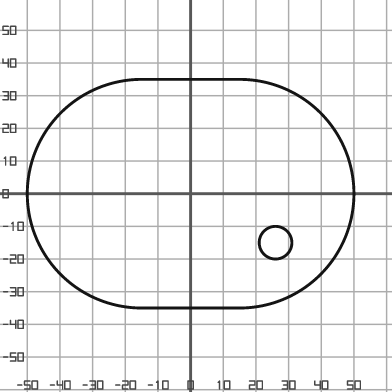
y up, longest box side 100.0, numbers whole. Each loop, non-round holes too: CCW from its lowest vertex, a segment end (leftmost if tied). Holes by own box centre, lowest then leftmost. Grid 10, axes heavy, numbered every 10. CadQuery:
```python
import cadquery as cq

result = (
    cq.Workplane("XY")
    .moveTo(-15.0, -35.0)
    .lineTo(15.0, -35.0)
    .threePointArc((50.0, 0.0), (15.0, 35.0))
    .lineTo(-15.0, 35.0)
    .threePointArc((-50.0, 0.0), (-15.0, -35.0))
    .close()
    .moveTo(26.0, -15.0)
    .circle(5.0)
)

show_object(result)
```